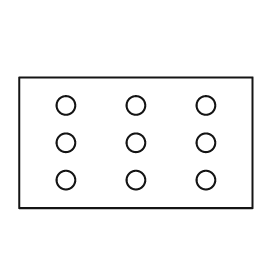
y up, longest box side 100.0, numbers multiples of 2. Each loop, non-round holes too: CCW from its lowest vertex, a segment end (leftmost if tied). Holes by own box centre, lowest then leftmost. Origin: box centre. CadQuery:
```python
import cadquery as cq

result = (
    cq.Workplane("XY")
    .moveTo(-50.0, -28.0)
    .lineTo(50.0, -28.0)
    .lineTo(50.0, 28.0)
    .lineTo(-50.0, 28.0)
    .close()
    .moveTo(-30.0, -16.0)
    .circle(4.0)
    .moveTo(0.0, -16.0)
    .circle(4.0)
    .moveTo(30.0, -16.0)
    .circle(4.0)
    .moveTo(-30.0, 0.0)
    .circle(4.0)
    .moveTo(0.0, 0.0)
    .circle(4.0)
    .moveTo(30.0, 0.0)
    .circle(4.0)
    .moveTo(-30.0, 16.0)
    .circle(4.0)
    .moveTo(0.0, 16.0)
    .circle(4.0)
    .moveTo(30.0, 16.0)
    .circle(4.0)
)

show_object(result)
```